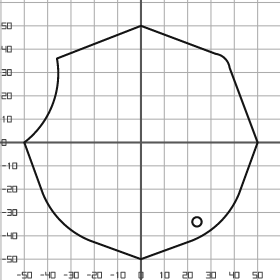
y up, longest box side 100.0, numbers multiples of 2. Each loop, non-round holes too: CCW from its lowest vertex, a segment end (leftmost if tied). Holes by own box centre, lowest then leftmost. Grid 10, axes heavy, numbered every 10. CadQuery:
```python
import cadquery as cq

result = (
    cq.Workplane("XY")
    .moveTo(0.0, -50.0)
    .lineTo(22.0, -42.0)
    .threePointArc((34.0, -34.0), (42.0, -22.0))
    .lineTo(50.0, 0.0)
    .lineTo(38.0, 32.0)
    .threePointArc((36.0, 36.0), (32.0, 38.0))
    .lineTo(0.0, 50.0)
    .lineTo(-36.0, 36.0)
    .threePointArc((-38.0, 16.0), (-50.0, 0.0))
    .lineTo(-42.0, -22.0)
    .threePointArc((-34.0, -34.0), (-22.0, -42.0))
    .close()
    .moveTo(24.0, -34.0)
    .circle(2.0)
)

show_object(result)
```